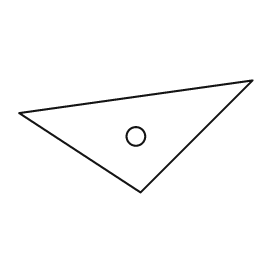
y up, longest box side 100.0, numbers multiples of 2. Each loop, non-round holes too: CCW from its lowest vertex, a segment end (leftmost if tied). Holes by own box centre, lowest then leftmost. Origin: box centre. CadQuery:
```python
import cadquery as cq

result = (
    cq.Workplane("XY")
    .moveTo(2.0, -24.0)
    .lineTo(50.0, 24.0)
    .lineTo(-50.0, 10.0)
    .close()
    .moveTo(0.0, 0.0)
    .circle(4.0)
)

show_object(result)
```